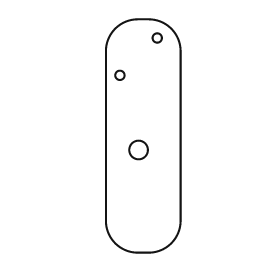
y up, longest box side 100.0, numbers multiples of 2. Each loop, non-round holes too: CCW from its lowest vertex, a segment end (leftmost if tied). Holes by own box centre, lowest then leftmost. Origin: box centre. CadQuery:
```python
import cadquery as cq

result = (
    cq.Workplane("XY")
    .moveTo(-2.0, -50.0)
    .lineTo(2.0, -50.0)
    .threePointArc((12.0, -46.0), (16.0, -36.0))
    .lineTo(16.0, 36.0)
    .threePointArc((12.0, 46.0), (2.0, 50.0))
    .lineTo(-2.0, 50.0)
    .threePointArc((-12.0, 46.0), (-16.0, 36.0))
    .lineTo(-16.0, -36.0)
    .threePointArc((-12.0, -46.0), (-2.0, -50.0))
    .close()
    .moveTo(-2.0, -6.0)
    .circle(4.0)
    .moveTo(-10.0, 26.0)
    .circle(2.0)
    .moveTo(6.0, 42.0)
    .circle(2.0)
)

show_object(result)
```